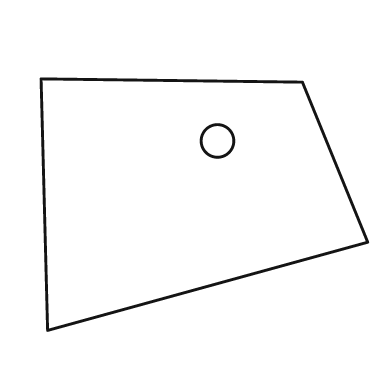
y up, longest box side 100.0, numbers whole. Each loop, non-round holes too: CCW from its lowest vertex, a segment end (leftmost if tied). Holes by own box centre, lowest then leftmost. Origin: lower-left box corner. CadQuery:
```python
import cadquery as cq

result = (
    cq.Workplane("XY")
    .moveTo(2.0, 0.0)
    .lineTo(100.0, 27.0)
    .lineTo(80.0, 76.0)
    .lineTo(0.0, 77.0)
    .close()
    .moveTo(54.0, 58.0)
    .circle(5.0)
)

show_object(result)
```